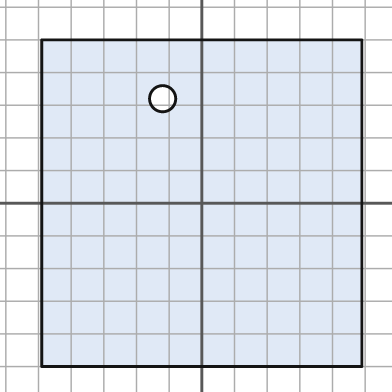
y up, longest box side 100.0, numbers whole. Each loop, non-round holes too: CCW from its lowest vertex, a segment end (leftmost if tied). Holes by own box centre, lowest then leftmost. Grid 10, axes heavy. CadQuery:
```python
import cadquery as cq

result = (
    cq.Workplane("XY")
    .moveTo(-49.0, -50.0)
    .lineTo(49.0, -50.0)
    .lineTo(49.0, 50.0)
    .lineTo(-49.0, 50.0)
    .close()
    .moveTo(-12.0, 32.0)
    .circle(4.0)
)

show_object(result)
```